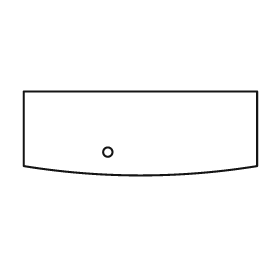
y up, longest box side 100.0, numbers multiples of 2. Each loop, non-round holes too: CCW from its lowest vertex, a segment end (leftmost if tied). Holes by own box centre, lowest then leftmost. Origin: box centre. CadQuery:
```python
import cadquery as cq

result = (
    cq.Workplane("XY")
    .moveTo(-50.0, -14.0)
    .threePointArc((0.0, -18.0), (50.0, -14.0))
    .lineTo(50.0, 18.0)
    .lineTo(-50.0, 18.0)
    .close()
    .moveTo(-14.0, -8.0)
    .circle(2.0)
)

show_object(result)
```